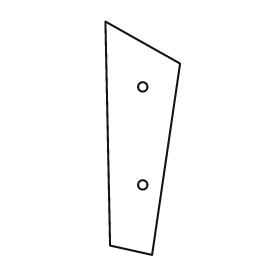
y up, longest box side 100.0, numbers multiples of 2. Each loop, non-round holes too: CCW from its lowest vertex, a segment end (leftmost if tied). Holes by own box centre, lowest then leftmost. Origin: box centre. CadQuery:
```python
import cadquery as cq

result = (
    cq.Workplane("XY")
    .moveTo(4.0, -50.0)
    .lineTo(16.0, 32.0)
    .lineTo(-16.0, 50.0)
    .lineTo(-14.0, -46.0)
    .close()
    .moveTo(0.0, -20.0)
    .circle(2.0)
    .moveTo(0.0, 22.0)
    .circle(2.0)
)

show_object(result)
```